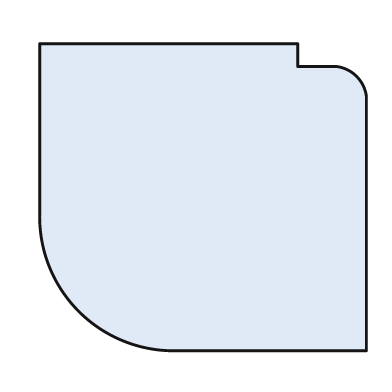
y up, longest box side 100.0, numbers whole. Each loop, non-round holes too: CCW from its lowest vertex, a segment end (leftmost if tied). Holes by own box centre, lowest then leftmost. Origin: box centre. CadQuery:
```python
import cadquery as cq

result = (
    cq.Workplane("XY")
    .moveTo(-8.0, -47.0)
    .lineTo(50.0, -47.0)
    .lineTo(50.0, 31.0)
    .threePointArc((47.0, 37.0), (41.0, 40.0))
    .lineTo(29.0, 40.0)
    .lineTo(29.0, 47.0)
    .lineTo(-50.0, 47.0)
    .lineTo(-50.0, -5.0)
    .threePointArc((-38.0, -35.0), (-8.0, -47.0))
    .close()
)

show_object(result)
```